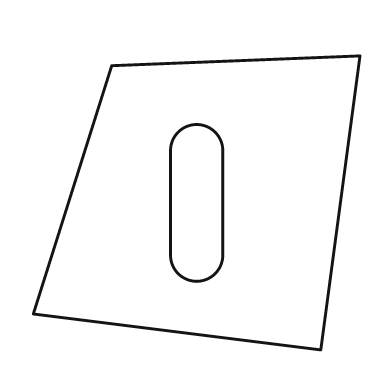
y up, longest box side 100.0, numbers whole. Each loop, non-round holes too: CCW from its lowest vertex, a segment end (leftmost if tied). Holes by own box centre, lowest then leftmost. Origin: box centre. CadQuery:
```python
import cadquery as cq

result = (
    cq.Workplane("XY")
    .moveTo(38.0, -45.0)
    .lineTo(50.0, 45.0)
    .lineTo(-26.0, 42.0)
    .lineTo(-50.0, -34.0)
    .close()
    .moveTo(-8.0, -16.0)
    .threePointArc((0.0, -24.0), (8.0, -16.0))
    .lineTo(8.0, 16.0)
    .threePointArc((0.0, 24.0), (-8.0, 16.0))
    .close()
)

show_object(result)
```